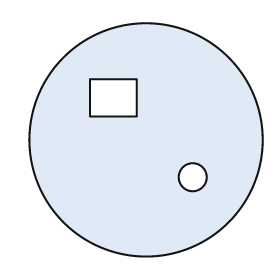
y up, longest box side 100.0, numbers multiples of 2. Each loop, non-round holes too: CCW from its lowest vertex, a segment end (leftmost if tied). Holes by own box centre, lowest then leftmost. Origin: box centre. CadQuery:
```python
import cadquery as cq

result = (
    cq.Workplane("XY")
    .moveTo(0.0, 0.0)
    .circle(50.0)
    .moveTo(20.0, -16.0)
    .circle(6.0)
    .moveTo(-24.0, 10.0)
    .lineTo(-4.0, 10.0)
    .lineTo(-4.0, 26.0)
    .lineTo(-24.0, 26.0)
    .close()
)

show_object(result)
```